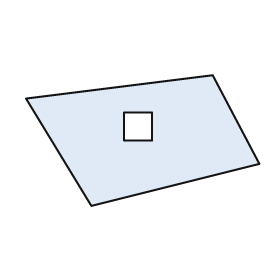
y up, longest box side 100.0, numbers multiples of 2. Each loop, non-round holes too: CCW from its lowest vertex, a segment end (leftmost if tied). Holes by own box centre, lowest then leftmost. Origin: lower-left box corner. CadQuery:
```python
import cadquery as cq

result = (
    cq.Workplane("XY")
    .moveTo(28.0, 0.0)
    .lineTo(100.0, 18.0)
    .lineTo(80.0, 56.0)
    .lineTo(0.0, 46.0)
    .close()
    .moveTo(42.0, 28.0)
    .lineTo(54.0, 28.0)
    .lineTo(54.0, 40.0)
    .lineTo(42.0, 40.0)
    .close()
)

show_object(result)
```